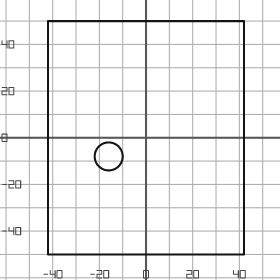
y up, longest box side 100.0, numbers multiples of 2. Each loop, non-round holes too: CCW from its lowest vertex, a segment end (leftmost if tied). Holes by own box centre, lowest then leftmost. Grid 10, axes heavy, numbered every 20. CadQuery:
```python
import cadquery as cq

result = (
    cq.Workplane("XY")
    .moveTo(-42.0, -50.0)
    .lineTo(42.0, -50.0)
    .lineTo(42.0, 50.0)
    .lineTo(-42.0, 50.0)
    .close()
    .moveTo(-16.0, -8.0)
    .circle(6.0)
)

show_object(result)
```